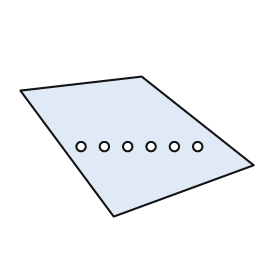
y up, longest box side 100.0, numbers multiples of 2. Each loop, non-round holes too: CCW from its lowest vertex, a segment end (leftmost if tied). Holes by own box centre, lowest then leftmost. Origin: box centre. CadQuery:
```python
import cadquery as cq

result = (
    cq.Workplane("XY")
    .moveTo(-10.0, -30.0)
    .lineTo(50.0, -8.0)
    .lineTo(2.0, 30.0)
    .lineTo(-50.0, 24.0)
    .close()
    .moveTo(-24.0, 0.0)
    .circle(2.0)
    .moveTo(-14.0, 0.0)
    .circle(2.0)
    .moveTo(-4.0, 0.0)
    .circle(2.0)
    .moveTo(6.0, 0.0)
    .circle(2.0)
    .moveTo(16.0, 0.0)
    .circle(2.0)
    .moveTo(26.0, 0.0)
    .circle(2.0)
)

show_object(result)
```